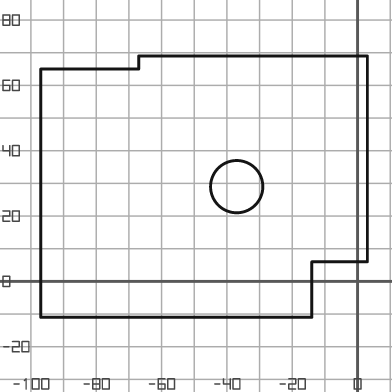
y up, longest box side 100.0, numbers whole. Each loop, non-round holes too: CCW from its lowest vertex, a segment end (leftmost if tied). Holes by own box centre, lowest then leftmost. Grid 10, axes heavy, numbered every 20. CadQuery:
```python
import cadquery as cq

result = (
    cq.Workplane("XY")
    .moveTo(-97.0, -11.0)
    .lineTo(-14.0, -11.0)
    .lineTo(-14.0, 6.0)
    .lineTo(3.0, 6.0)
    .lineTo(3.0, 69.0)
    .lineTo(-67.0, 69.0)
    .lineTo(-67.0, 65.0)
    .lineTo(-97.0, 65.0)
    .close()
    .moveTo(-37.0, 29.0)
    .circle(8.0)
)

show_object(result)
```